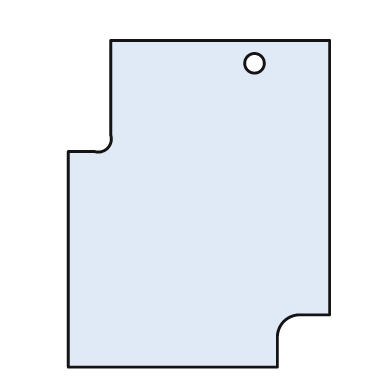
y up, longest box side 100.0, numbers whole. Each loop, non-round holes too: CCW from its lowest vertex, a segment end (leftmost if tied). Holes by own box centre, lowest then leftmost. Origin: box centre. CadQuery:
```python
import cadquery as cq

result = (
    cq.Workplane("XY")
    .moveTo(-40.0, -50.0)
    .lineTo(24.0, -50.0)
    .lineTo(24.0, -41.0)
    .threePointArc((26.0, -36.0), (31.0, -34.0))
    .lineTo(40.0, -34.0)
    .lineTo(40.0, 50.0)
    .lineTo(-27.0, 50.0)
    .lineTo(-27.0, 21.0)
    .threePointArc((-28.0, 17.0), (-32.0, 16.0))
    .lineTo(-40.0, 16.0)
    .close()
    .moveTo(17.0, 43.0)
    .circle(3.0)
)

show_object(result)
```